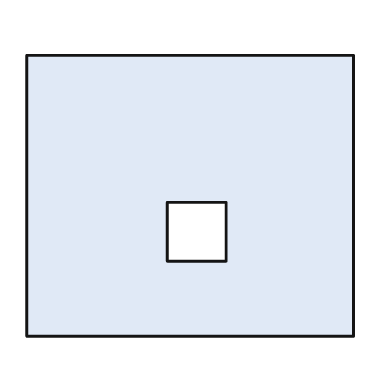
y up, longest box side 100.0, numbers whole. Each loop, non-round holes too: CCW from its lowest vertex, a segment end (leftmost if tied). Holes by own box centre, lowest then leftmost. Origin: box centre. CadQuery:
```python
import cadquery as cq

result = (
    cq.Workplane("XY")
    .moveTo(-50.0, -43.0)
    .lineTo(50.0, -43.0)
    .lineTo(50.0, 43.0)
    .lineTo(-50.0, 43.0)
    .close()
    .moveTo(-7.0, -20.0)
    .lineTo(11.0, -20.0)
    .lineTo(11.0, -2.0)
    .lineTo(-7.0, -2.0)
    .close()
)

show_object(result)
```